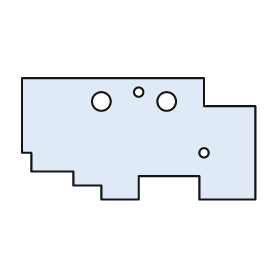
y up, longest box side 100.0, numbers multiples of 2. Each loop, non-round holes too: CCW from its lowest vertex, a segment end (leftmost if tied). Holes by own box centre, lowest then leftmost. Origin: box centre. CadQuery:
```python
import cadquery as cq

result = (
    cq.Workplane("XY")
    .moveTo(-16.0, -26.0)
    .lineTo(0.0, -26.0)
    .lineTo(0.0, -16.0)
    .lineTo(26.0, -16.0)
    .lineTo(26.0, -26.0)
    .lineTo(50.0, -26.0)
    .lineTo(50.0, 14.0)
    .lineTo(28.0, 14.0)
    .lineTo(28.0, 26.0)
    .lineTo(-50.0, 26.0)
    .lineTo(-50.0, -6.0)
    .lineTo(-46.0, -6.0)
    .lineTo(-46.0, -14.0)
    .lineTo(-28.0, -14.0)
    .lineTo(-28.0, -20.0)
    .lineTo(-16.0, -20.0)
    .close()
    .moveTo(28.0, -6.0)
    .circle(2.0)
    .moveTo(-16.0, 16.0)
    .circle(4.0)
    .moveTo(12.0, 16.0)
    .circle(4.0)
    .moveTo(0.0, 20.0)
    .circle(2.0)
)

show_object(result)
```